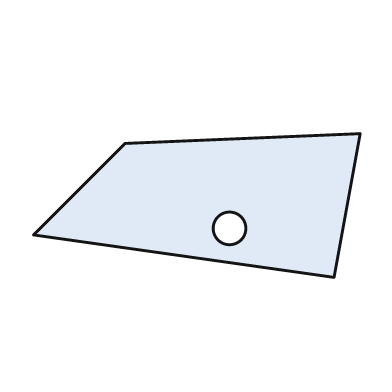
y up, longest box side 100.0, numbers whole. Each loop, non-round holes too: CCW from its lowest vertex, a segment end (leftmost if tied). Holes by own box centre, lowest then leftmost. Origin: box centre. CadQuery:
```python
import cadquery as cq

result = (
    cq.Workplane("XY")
    .moveTo(42.0, -22.0)
    .lineTo(50.0, 22.0)
    .lineTo(-22.0, 19.0)
    .lineTo(-50.0, -9.0)
    .close()
    .moveTo(10.0, -7.0)
    .circle(5.0)
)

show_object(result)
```